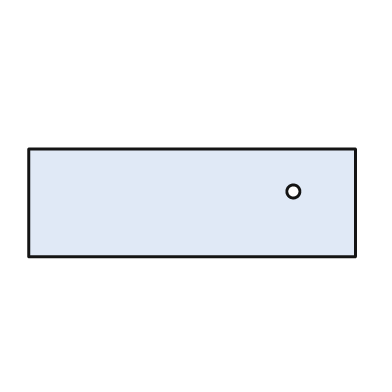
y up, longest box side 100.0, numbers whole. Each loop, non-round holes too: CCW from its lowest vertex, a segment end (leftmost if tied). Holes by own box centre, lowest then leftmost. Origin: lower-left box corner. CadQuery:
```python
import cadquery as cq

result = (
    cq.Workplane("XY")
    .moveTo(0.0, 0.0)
    .lineTo(100.0, 0.0)
    .lineTo(100.0, 33.0)
    .lineTo(0.0, 33.0)
    .close()
    .moveTo(81.0, 20.0)
    .circle(2.0)
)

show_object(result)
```